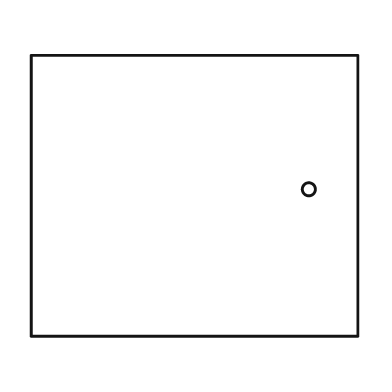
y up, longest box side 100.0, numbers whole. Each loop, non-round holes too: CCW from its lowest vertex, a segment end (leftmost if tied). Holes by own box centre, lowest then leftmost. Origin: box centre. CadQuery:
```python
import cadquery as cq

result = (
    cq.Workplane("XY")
    .moveTo(-50.0, -43.0)
    .lineTo(50.0, -43.0)
    .lineTo(50.0, 43.0)
    .lineTo(-50.0, 43.0)
    .close()
    .moveTo(35.0, 2.0)
    .circle(2.0)
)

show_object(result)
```